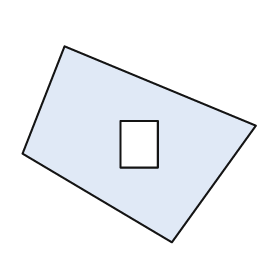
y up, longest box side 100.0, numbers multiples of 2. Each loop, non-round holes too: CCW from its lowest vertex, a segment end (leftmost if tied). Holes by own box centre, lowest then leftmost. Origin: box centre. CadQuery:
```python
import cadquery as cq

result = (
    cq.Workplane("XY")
    .moveTo(14.0, -42.0)
    .lineTo(50.0, 8.0)
    .lineTo(-32.0, 42.0)
    .lineTo(-50.0, -4.0)
    .close()
    .moveTo(-8.0, -10.0)
    .lineTo(8.0, -10.0)
    .lineTo(8.0, 10.0)
    .lineTo(-8.0, 10.0)
    .close()
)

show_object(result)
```